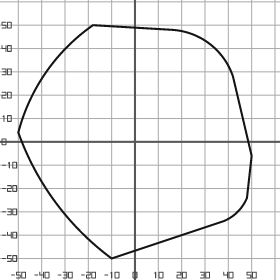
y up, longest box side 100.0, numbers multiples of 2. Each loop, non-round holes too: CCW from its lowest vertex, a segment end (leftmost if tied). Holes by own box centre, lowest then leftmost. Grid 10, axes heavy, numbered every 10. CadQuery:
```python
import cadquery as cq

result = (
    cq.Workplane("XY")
    .moveTo(-10.0, -50.0)
    .lineTo(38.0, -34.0)
    .threePointArc((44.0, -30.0), (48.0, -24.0))
    .lineTo(50.0, -6.0)
    .lineTo(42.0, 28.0)
    .threePointArc((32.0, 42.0), (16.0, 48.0))
    .lineTo(-18.0, 50.0)
    .threePointArc((-38.0, 30.0), (-50.0, 4.0))
    .threePointArc((-34.0, -26.0), (-10.0, -50.0))
    .close()
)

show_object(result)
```